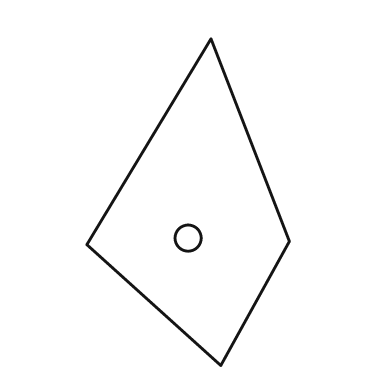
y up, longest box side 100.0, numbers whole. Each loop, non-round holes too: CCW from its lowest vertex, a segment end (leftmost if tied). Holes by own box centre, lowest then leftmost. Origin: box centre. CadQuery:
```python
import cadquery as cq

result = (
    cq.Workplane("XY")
    .moveTo(10.0, -50.0)
    .lineTo(31.0, -12.0)
    .lineTo(7.0, 50.0)
    .lineTo(-31.0, -13.0)
    .close()
    .moveTo(0.0, -11.0)
    .circle(4.0)
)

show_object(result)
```